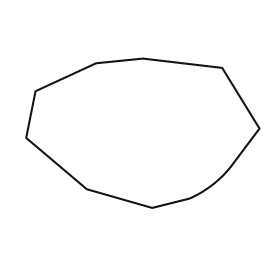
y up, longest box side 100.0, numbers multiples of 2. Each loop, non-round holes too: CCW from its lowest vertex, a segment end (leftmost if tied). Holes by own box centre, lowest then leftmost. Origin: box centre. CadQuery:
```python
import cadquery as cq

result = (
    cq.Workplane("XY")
    .moveTo(4.0, -32.0)
    .lineTo(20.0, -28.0)
    .threePointArc((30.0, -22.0), (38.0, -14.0))
    .lineTo(50.0, 2.0)
    .lineTo(34.0, 28.0)
    .lineTo(0.0, 32.0)
    .lineTo(-20.0, 30.0)
    .lineTo(-46.0, 18.0)
    .lineTo(-50.0, -2.0)
    .lineTo(-24.0, -24.0)
    .close()
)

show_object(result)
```